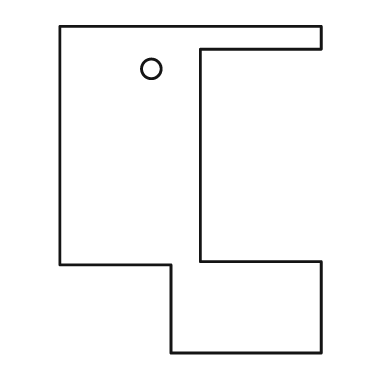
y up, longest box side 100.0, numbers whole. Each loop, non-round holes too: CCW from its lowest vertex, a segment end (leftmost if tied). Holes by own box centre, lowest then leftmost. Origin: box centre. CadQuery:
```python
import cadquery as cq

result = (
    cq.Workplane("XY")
    .moveTo(-6.0, -50.0)
    .lineTo(40.0, -50.0)
    .lineTo(40.0, -22.0)
    .lineTo(3.0, -22.0)
    .lineTo(3.0, 43.0)
    .lineTo(40.0, 43.0)
    .lineTo(40.0, 50.0)
    .lineTo(-40.0, 50.0)
    .lineTo(-40.0, -23.0)
    .lineTo(-6.0, -23.0)
    .close()
    .moveTo(-12.0, 37.0)
    .circle(3.0)
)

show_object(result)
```